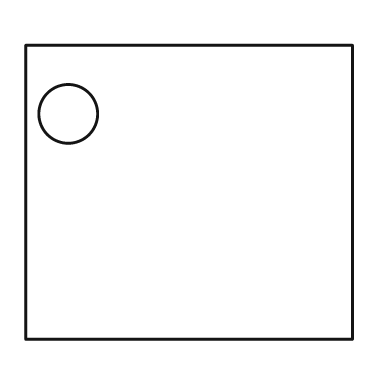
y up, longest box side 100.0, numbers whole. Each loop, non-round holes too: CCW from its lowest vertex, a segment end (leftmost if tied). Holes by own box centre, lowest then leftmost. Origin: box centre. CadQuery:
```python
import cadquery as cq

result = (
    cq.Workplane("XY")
    .moveTo(-50.0, -45.0)
    .lineTo(50.0, -45.0)
    .lineTo(50.0, 45.0)
    .lineTo(-50.0, 45.0)
    .close()
    .moveTo(-37.0, 24.0)
    .circle(9.0)
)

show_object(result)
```